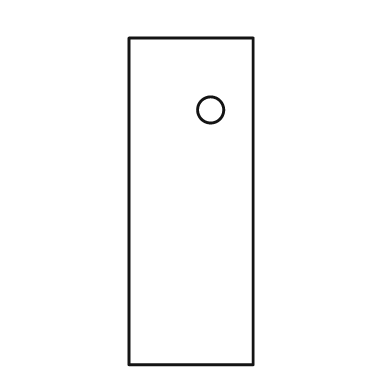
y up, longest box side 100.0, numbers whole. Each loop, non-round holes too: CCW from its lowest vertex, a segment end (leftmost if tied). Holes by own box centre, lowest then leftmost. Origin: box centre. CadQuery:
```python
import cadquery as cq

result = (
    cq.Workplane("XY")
    .moveTo(-19.0, -50.0)
    .lineTo(19.0, -50.0)
    .lineTo(19.0, 50.0)
    .lineTo(-19.0, 50.0)
    .close()
    .moveTo(6.0, 28.0)
    .circle(4.0)
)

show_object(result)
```